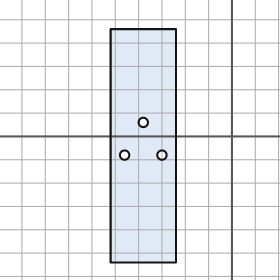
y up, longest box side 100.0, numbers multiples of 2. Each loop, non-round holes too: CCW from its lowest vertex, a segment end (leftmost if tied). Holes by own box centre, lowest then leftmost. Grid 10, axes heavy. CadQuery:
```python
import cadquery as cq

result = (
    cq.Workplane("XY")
    .moveTo(-52.0, -54.0)
    .lineTo(-24.0, -54.0)
    .lineTo(-24.0, 46.0)
    .lineTo(-52.0, 46.0)
    .close()
    .moveTo(-46.0, -8.0)
    .circle(2.0)
    .moveTo(-30.0, -8.0)
    .circle(2.0)
    .moveTo(-38.0, 6.0)
    .circle(2.0)
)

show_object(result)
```